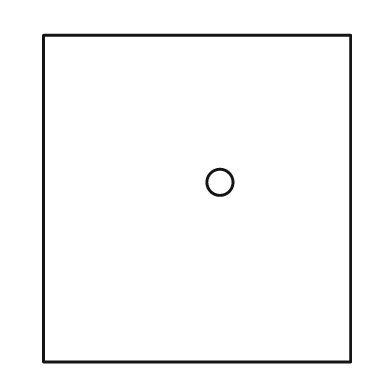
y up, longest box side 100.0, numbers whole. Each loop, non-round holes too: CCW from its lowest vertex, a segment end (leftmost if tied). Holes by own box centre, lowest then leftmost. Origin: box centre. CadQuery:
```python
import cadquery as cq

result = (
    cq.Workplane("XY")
    .moveTo(-47.0, -50.0)
    .lineTo(47.0, -50.0)
    .lineTo(47.0, 50.0)
    .lineTo(-47.0, 50.0)
    .close()
    .moveTo(7.0, 5.0)
    .circle(4.0)
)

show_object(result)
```